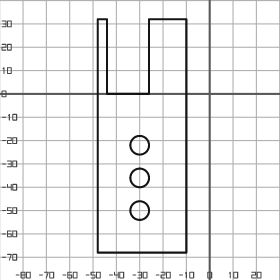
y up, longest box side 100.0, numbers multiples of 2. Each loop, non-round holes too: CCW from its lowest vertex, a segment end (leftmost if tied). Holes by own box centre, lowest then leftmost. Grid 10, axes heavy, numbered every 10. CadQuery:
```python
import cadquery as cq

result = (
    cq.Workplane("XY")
    .moveTo(-48.0, -68.0)
    .lineTo(-10.0, -68.0)
    .lineTo(-10.0, 32.0)
    .lineTo(-26.0, 32.0)
    .lineTo(-26.0, 0.0)
    .lineTo(-44.0, 0.0)
    .lineTo(-44.0, 32.0)
    .lineTo(-48.0, 32.0)
    .close()
    .moveTo(-30.0, -50.0)
    .circle(4.0)
    .moveTo(-30.0, -36.0)
    .circle(4.0)
    .moveTo(-30.0, -22.0)
    .circle(4.0)
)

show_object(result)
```